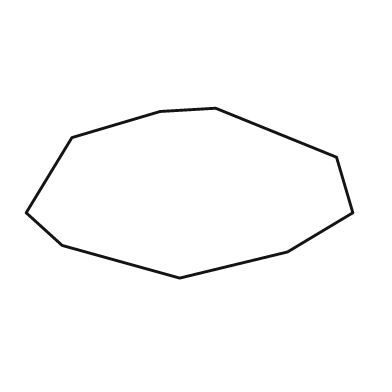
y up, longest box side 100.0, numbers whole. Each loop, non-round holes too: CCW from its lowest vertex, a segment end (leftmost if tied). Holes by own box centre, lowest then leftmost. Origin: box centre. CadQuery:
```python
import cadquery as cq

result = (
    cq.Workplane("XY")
    .moveTo(-3.0, -26.0)
    .lineTo(30.0, -18.0)
    .lineTo(50.0, -6.0)
    .lineTo(45.0, 11.0)
    .lineTo(8.0, 26.0)
    .lineTo(-9.0, 25.0)
    .lineTo(-36.0, 17.0)
    .lineTo(-50.0, -6.0)
    .lineTo(-39.0, -16.0)
    .close()
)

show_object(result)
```